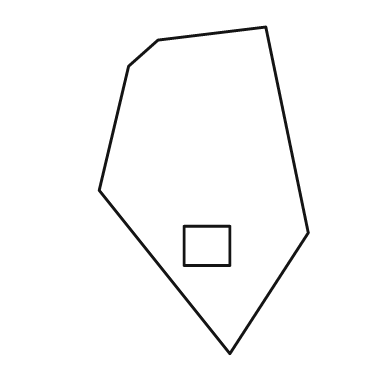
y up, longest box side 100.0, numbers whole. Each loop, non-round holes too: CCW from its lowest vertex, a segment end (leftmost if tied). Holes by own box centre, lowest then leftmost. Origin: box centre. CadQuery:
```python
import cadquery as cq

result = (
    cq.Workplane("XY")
    .moveTo(8.0, -50.0)
    .lineTo(32.0, -13.0)
    .lineTo(19.0, 50.0)
    .lineTo(-14.0, 46.0)
    .lineTo(-23.0, 38.0)
    .lineTo(-32.0, 0.0)
    .close()
    .moveTo(-6.0, -23.0)
    .lineTo(8.0, -23.0)
    .lineTo(8.0, -11.0)
    .lineTo(-6.0, -11.0)
    .close()
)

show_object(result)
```